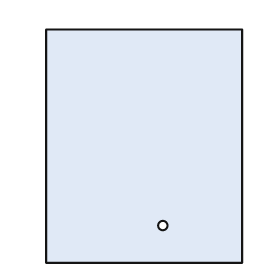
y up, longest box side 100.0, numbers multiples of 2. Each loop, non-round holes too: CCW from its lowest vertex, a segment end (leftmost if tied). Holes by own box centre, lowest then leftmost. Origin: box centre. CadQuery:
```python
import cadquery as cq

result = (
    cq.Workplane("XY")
    .moveTo(-42.0, -50.0)
    .lineTo(42.0, -50.0)
    .lineTo(42.0, 50.0)
    .lineTo(-42.0, 50.0)
    .close()
    .moveTo(8.0, -34.0)
    .circle(2.0)
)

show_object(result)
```